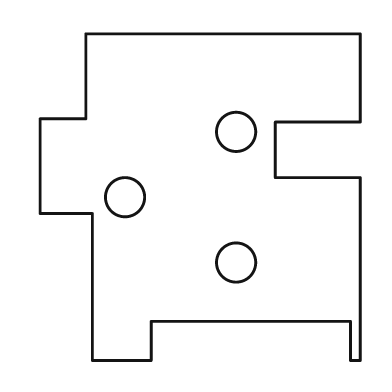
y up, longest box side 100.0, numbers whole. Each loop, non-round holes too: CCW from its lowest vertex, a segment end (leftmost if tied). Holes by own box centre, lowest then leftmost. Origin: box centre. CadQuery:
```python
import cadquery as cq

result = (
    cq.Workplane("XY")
    .moveTo(-33.0, -50.0)
    .lineTo(-15.0, -50.0)
    .lineTo(-15.0, -38.0)
    .lineTo(46.0, -38.0)
    .lineTo(46.0, -50.0)
    .lineTo(49.0, -50.0)
    .lineTo(49.0, 6.0)
    .lineTo(23.0, 6.0)
    .lineTo(23.0, 23.0)
    .lineTo(49.0, 23.0)
    .lineTo(49.0, 50.0)
    .lineTo(-35.0, 50.0)
    .lineTo(-35.0, 24.0)
    .lineTo(-49.0, 24.0)
    .lineTo(-49.0, -5.0)
    .lineTo(-33.0, -5.0)
    .close()
    .moveTo(11.0, -20.0)
    .circle(6.0)
    .moveTo(-23.0, 0.0)
    .circle(6.0)
    .moveTo(11.0, 20.0)
    .circle(6.0)
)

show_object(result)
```